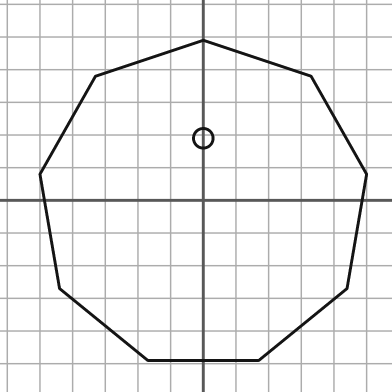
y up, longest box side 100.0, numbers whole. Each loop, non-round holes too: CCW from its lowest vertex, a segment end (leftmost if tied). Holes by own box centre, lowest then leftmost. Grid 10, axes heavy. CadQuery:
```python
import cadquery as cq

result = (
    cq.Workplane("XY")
    .moveTo(-17.0, -49.0)
    .lineTo(17.0, -49.0)
    .lineTo(44.0, -27.0)
    .lineTo(50.0, 8.0)
    .lineTo(33.0, 38.0)
    .lineTo(0.0, 49.0)
    .lineTo(-33.0, 38.0)
    .lineTo(-50.0, 8.0)
    .lineTo(-44.0, -27.0)
    .close()
    .moveTo(0.0, 19.0)
    .circle(3.0)
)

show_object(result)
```